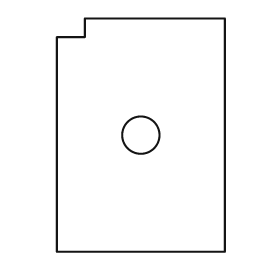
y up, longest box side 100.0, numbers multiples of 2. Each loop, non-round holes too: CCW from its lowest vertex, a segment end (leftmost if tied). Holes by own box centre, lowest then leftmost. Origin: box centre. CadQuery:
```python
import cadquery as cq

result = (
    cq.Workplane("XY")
    .moveTo(-36.0, -50.0)
    .lineTo(36.0, -50.0)
    .lineTo(36.0, 50.0)
    .lineTo(-24.0, 50.0)
    .lineTo(-24.0, 42.0)
    .lineTo(-36.0, 42.0)
    .close()
    .moveTo(0.0, 0.0)
    .circle(8.0)
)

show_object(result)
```